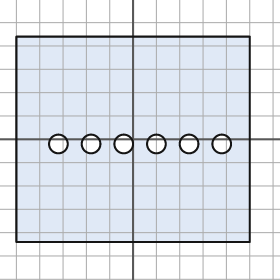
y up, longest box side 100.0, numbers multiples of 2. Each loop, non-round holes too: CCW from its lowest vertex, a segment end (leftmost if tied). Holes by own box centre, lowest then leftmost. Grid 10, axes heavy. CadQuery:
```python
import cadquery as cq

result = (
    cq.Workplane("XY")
    .moveTo(-50.0, -44.0)
    .lineTo(50.0, -44.0)
    .lineTo(50.0, 44.0)
    .lineTo(-50.0, 44.0)
    .close()
    .moveTo(-32.0, -2.0)
    .circle(4.0)
    .moveTo(-18.0, -2.0)
    .circle(4.0)
    .moveTo(-4.0, -2.0)
    .circle(4.0)
    .moveTo(10.0, -2.0)
    .circle(4.0)
    .moveTo(24.0, -2.0)
    .circle(4.0)
    .moveTo(38.0, -2.0)
    .circle(4.0)
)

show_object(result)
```